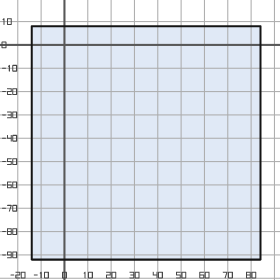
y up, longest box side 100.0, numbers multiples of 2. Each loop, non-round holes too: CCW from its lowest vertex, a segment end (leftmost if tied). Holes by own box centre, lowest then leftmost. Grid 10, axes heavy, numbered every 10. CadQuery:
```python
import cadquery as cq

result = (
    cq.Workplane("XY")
    .moveTo(-14.0, -92.0)
    .lineTo(84.0, -92.0)
    .lineTo(84.0, 8.0)
    .lineTo(-14.0, 8.0)
    .close()
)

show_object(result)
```